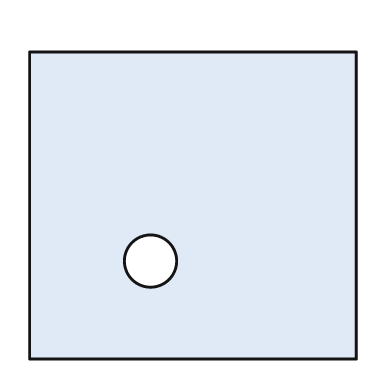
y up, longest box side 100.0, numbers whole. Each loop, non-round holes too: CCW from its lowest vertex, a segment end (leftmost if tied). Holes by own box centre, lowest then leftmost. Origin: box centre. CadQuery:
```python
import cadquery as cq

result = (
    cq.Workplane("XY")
    .moveTo(-50.0, -47.0)
    .lineTo(50.0, -47.0)
    .lineTo(50.0, 47.0)
    .lineTo(-50.0, 47.0)
    .close()
    .moveTo(-13.0, -17.0)
    .circle(8.0)
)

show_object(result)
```